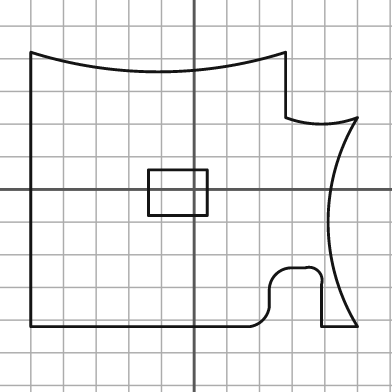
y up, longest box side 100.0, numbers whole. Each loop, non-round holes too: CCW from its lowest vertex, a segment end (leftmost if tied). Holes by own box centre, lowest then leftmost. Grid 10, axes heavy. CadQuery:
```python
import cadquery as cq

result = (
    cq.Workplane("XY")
    .moveTo(-50.0, -42.0)
    .lineTo(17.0, -42.0)
    .threePointArc((21.0, -40.0), (23.0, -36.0))
    .lineTo(23.0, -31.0)
    .threePointArc((25.0, -26.0), (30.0, -24.0))
    .lineTo(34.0, -24.0)
    .threePointArc((38.0, -25.0), (39.0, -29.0))
    .lineTo(39.0, -42.0)
    .lineTo(50.0, -42.0)
    .threePointArc((41.0, -10.0), (50.0, 22.0))
    .threePointArc((39.0, 20.0), (28.0, 22.0))
    .lineTo(28.0, 42.0)
    .threePointArc((-11.0, 36.0), (-50.0, 42.0))
    .close()
    .moveTo(-14.0, -8.0)
    .lineTo(4.0, -8.0)
    .lineTo(4.0, 6.0)
    .lineTo(-14.0, 6.0)
    .close()
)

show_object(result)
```